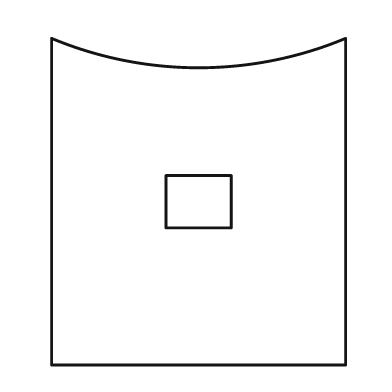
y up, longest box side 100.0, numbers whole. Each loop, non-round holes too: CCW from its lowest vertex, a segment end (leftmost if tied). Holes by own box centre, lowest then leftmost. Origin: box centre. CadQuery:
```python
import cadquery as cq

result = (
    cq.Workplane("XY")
    .moveTo(-45.0, -50.0)
    .lineTo(45.0, -50.0)
    .lineTo(45.0, 50.0)
    .threePointArc((0.0, 41.0), (-45.0, 50.0))
    .close()
    .moveTo(-10.0, -8.0)
    .lineTo(10.0, -8.0)
    .lineTo(10.0, 8.0)
    .lineTo(-10.0, 8.0)
    .close()
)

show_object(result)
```